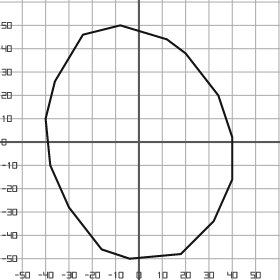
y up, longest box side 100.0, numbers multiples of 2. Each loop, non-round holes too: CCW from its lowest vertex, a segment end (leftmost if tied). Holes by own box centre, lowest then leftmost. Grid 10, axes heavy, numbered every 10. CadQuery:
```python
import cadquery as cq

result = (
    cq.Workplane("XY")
    .moveTo(-4.0, -50.0)
    .lineTo(18.0, -48.0)
    .lineTo(32.0, -34.0)
    .lineTo(40.0, -16.0)
    .lineTo(40.0, 2.0)
    .lineTo(34.0, 20.0)
    .lineTo(20.0, 38.0)
    .lineTo(12.0, 44.0)
    .lineTo(-8.0, 50.0)
    .lineTo(-24.0, 46.0)
    .lineTo(-36.0, 26.0)
    .lineTo(-40.0, 10.0)
    .lineTo(-38.0, -10.0)
    .lineTo(-30.0, -28.0)
    .lineTo(-16.0, -46.0)
    .close()
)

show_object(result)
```